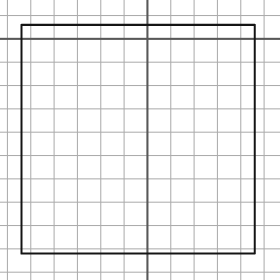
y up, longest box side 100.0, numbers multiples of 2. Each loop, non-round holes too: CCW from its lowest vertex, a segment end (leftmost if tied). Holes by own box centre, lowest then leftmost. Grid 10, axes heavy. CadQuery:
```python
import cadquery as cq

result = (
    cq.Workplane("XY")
    .moveTo(-54.0, -92.0)
    .lineTo(46.0, -92.0)
    .lineTo(46.0, 6.0)
    .lineTo(-54.0, 6.0)
    .close()
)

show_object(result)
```